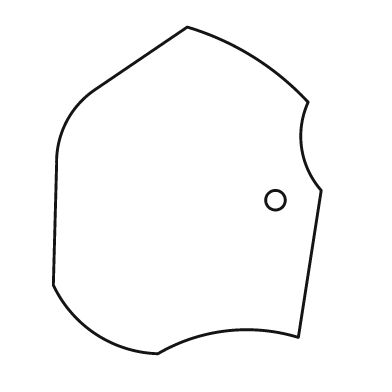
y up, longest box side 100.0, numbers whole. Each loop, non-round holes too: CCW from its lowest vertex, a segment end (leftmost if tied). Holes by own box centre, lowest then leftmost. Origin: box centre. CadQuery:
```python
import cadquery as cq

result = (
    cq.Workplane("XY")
    .moveTo(-9.0, -50.0)
    .threePointArc((12.0, -43.0), (34.0, -45.0))
    .lineTo(41.0, 0.0)
    .threePointArc((35.0, 13.0), (37.0, 27.0))
    .threePointArc((20.0, 41.0), (0.0, 50.0))
    .lineTo(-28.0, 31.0)
    .threePointArc((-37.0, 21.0), (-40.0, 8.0))
    .lineTo(-41.0, -29.0)
    .threePointArc((-28.0, -44.0), (-9.0, -50.0))
    .close()
    .moveTo(27.0, -3.0)
    .circle(3.0)
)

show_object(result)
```